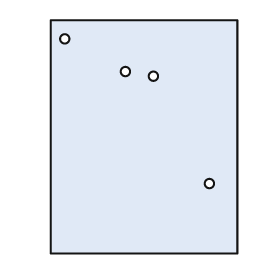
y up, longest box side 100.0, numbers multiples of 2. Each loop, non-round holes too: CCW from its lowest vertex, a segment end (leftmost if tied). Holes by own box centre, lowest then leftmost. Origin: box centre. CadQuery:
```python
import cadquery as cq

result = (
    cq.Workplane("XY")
    .moveTo(-40.0, -50.0)
    .lineTo(40.0, -50.0)
    .lineTo(40.0, 50.0)
    .lineTo(-40.0, 50.0)
    .close()
    .moveTo(28.0, -20.0)
    .circle(2.0)
    .moveTo(4.0, 26.0)
    .circle(2.0)
    .moveTo(-8.0, 28.0)
    .circle(2.0)
    .moveTo(-34.0, 42.0)
    .circle(2.0)
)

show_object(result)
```